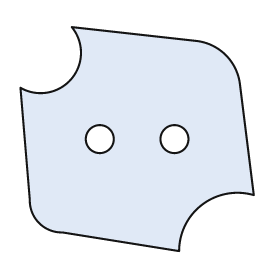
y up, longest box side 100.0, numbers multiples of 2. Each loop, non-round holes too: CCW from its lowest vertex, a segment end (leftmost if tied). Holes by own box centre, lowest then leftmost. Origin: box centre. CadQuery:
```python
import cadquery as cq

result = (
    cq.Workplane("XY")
    .moveTo(18.0, -48.0)
    .threePointArc((28.0, -28.0), (50.0, -24.0))
    .lineTo(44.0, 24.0)
    .threePointArc((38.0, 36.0), (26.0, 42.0))
    .lineTo(-28.0, 48.0)
    .threePointArc((-28.0, 26.0), (-50.0, 22.0))
    .lineTo(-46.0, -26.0)
    .threePointArc((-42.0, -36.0), (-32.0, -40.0))
    .close()
    .moveTo(-16.0, 0.0)
    .circle(6.0)
    .moveTo(16.0, 0.0)
    .circle(6.0)
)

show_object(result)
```